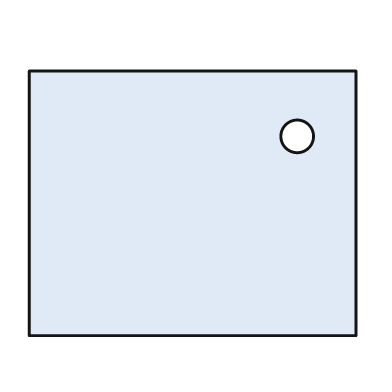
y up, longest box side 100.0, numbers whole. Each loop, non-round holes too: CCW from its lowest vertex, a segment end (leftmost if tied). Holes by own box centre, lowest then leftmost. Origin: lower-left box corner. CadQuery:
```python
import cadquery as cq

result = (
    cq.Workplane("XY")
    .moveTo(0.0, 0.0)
    .lineTo(100.0, 0.0)
    .lineTo(100.0, 81.0)
    .lineTo(0.0, 81.0)
    .close()
    .moveTo(82.0, 61.0)
    .circle(5.0)
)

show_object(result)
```